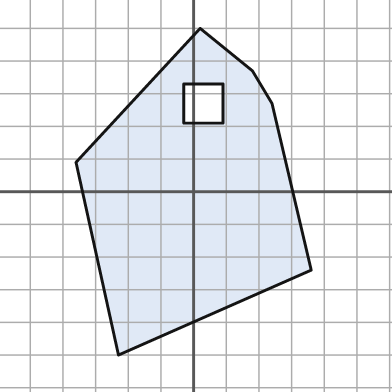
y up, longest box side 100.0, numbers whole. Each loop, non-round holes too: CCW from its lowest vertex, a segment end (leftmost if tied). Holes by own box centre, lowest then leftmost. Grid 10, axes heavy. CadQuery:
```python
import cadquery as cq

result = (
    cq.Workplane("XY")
    .moveTo(-23.0, -50.0)
    .lineTo(36.0, -24.0)
    .lineTo(24.0, 27.0)
    .lineTo(18.0, 37.0)
    .lineTo(2.0, 50.0)
    .lineTo(-36.0, 9.0)
    .close()
    .moveTo(-3.0, 21.0)
    .lineTo(9.0, 21.0)
    .lineTo(9.0, 33.0)
    .lineTo(-3.0, 33.0)
    .close()
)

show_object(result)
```